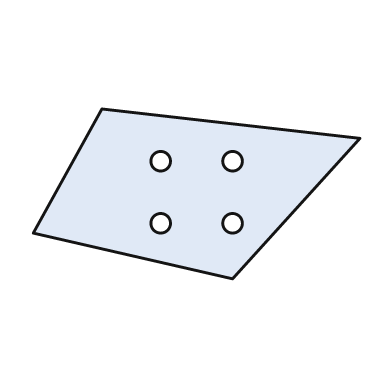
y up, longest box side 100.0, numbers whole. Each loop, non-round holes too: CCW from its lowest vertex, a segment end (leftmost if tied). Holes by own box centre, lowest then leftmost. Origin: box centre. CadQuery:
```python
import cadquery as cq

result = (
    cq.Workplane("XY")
    .moveTo(11.0, -26.0)
    .lineTo(50.0, 17.0)
    .lineTo(-29.0, 26.0)
    .lineTo(-50.0, -12.0)
    .close()
    .moveTo(-11.0, -9.0)
    .circle(3.0)
    .moveTo(11.0, -9.0)
    .circle(3.0)
    .moveTo(-11.0, 10.0)
    .circle(3.0)
    .moveTo(11.0, 10.0)
    .circle(3.0)
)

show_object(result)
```